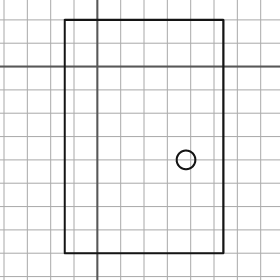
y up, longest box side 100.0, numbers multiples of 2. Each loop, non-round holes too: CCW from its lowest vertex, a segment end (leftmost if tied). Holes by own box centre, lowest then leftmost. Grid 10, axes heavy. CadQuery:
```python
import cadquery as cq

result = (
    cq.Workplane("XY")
    .moveTo(-14.0, -80.0)
    .lineTo(54.0, -80.0)
    .lineTo(54.0, 20.0)
    .lineTo(-14.0, 20.0)
    .close()
    .moveTo(38.0, -40.0)
    .circle(4.0)
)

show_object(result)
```